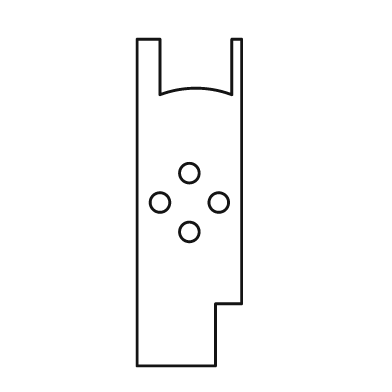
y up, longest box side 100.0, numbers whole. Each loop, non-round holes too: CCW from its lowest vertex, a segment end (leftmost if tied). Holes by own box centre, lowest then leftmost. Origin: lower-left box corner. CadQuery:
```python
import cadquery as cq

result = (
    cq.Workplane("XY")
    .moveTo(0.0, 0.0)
    .lineTo(24.0, 0.0)
    .lineTo(24.0, 19.0)
    .lineTo(32.0, 19.0)
    .lineTo(32.0, 100.0)
    .lineTo(29.0, 100.0)
    .lineTo(29.0, 83.0)
    .threePointArc((18.0, 85.0), (7.0, 83.0))
    .lineTo(7.0, 100.0)
    .lineTo(0.0, 100.0)
    .close()
    .moveTo(16.0, 41.0)
    .circle(3.0)
    .moveTo(7.0, 50.0)
    .circle(3.0)
    .moveTo(25.0, 50.0)
    .circle(3.0)
    .moveTo(16.0, 59.0)
    .circle(3.0)
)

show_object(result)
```